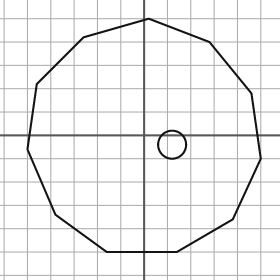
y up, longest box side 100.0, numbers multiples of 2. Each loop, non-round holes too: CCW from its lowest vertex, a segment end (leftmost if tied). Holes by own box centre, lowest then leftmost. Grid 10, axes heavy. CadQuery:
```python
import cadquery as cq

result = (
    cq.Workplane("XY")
    .moveTo(-16.0, -50.0)
    .lineTo(14.0, -50.0)
    .lineTo(38.0, -36.0)
    .lineTo(50.0, -10.0)
    .lineTo(46.0, 18.0)
    .lineTo(28.0, 40.0)
    .lineTo(2.0, 50.0)
    .lineTo(-26.0, 42.0)
    .lineTo(-46.0, 22.0)
    .lineTo(-50.0, -6.0)
    .lineTo(-38.0, -34.0)
    .close()
    .moveTo(12.0, -4.0)
    .circle(6.0)
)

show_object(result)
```